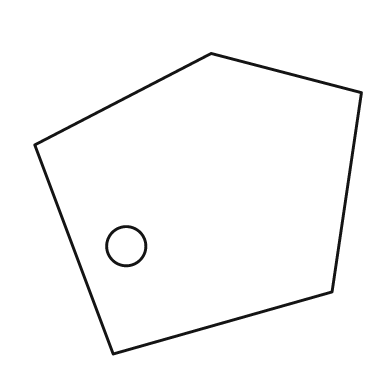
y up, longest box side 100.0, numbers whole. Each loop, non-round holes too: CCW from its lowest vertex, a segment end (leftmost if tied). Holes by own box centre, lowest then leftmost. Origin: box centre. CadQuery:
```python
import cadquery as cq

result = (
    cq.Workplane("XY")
    .moveTo(-26.0, -46.0)
    .lineTo(41.0, -27.0)
    .lineTo(50.0, 34.0)
    .lineTo(4.0, 46.0)
    .lineTo(-50.0, 18.0)
    .close()
    .moveTo(-22.0, -13.0)
    .circle(6.0)
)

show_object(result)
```